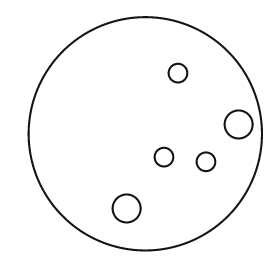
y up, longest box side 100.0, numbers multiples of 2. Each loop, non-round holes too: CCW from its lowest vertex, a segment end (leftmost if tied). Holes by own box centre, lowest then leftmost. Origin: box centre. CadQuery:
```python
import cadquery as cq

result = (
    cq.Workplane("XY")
    .moveTo(0.0, 0.0)
    .circle(50.0)
    .moveTo(-8.0, -32.0)
    .circle(6.0)
    .moveTo(26.0, -12.0)
    .circle(4.0)
    .moveTo(8.0, -10.0)
    .circle(4.0)
    .moveTo(40.0, 4.0)
    .circle(6.0)
    .moveTo(14.0, 26.0)
    .circle(4.0)
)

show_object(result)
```